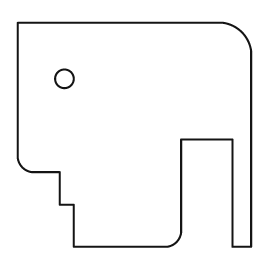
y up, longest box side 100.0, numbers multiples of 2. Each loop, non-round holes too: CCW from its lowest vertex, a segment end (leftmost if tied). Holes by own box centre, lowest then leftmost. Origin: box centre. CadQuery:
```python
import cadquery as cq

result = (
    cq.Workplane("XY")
    .moveTo(-26.0, -48.0)
    .lineTo(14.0, -48.0)
    .threePointArc((18.0, -46.0), (20.0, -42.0))
    .lineTo(20.0, -2.0)
    .lineTo(42.0, -2.0)
    .lineTo(42.0, -48.0)
    .lineTo(50.0, -48.0)
    .lineTo(50.0, 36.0)
    .threePointArc((46.0, 44.0), (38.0, 48.0))
    .lineTo(-50.0, 48.0)
    .lineTo(-50.0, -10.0)
    .threePointArc((-48.0, -14.0), (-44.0, -16.0))
    .lineTo(-32.0, -16.0)
    .lineTo(-32.0, -30.0)
    .lineTo(-26.0, -30.0)
    .close()
    .moveTo(-30.0, 24.0)
    .circle(4.0)
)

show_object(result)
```